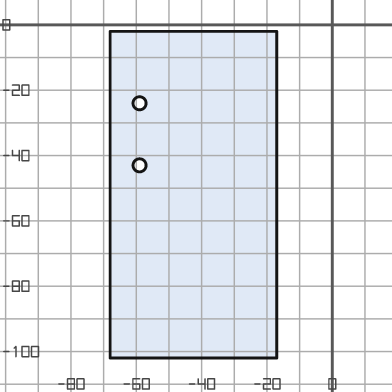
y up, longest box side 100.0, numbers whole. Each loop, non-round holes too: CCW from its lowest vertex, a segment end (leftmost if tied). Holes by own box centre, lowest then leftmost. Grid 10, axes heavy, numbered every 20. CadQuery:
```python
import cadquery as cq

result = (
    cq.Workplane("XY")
    .moveTo(-68.0, -102.0)
    .lineTo(-17.0, -102.0)
    .lineTo(-17.0, -2.0)
    .lineTo(-68.0, -2.0)
    .close()
    .moveTo(-59.0, -43.0)
    .circle(2.0)
    .moveTo(-59.0, -24.0)
    .circle(2.0)
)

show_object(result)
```